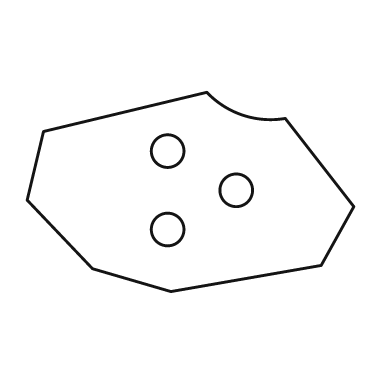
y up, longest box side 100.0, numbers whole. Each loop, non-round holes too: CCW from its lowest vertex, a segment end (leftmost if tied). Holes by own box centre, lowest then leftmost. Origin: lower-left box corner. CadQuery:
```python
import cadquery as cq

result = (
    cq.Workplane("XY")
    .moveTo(44.0, 0.0)
    .lineTo(90.0, 8.0)
    .lineTo(100.0, 26.0)
    .lineTo(79.0, 53.0)
    .threePointArc((66.0, 54.0), (55.0, 61.0))
    .lineTo(5.0, 49.0)
    .lineTo(0.0, 28.0)
    .lineTo(20.0, 7.0)
    .close()
    .moveTo(43.0, 19.0)
    .circle(5.0)
    .moveTo(64.0, 31.0)
    .circle(5.0)
    .moveTo(43.0, 43.0)
    .circle(5.0)
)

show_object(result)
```